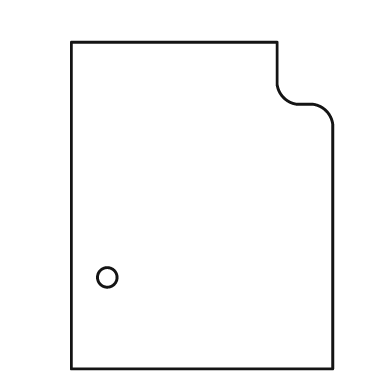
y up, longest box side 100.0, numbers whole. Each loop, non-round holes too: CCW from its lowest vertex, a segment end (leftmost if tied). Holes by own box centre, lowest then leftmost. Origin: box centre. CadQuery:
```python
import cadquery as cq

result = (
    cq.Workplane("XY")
    .moveTo(-40.0, -50.0)
    .lineTo(40.0, -50.0)
    .lineTo(40.0, 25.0)
    .threePointArc((38.0, 29.0), (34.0, 31.0))
    .lineTo(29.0, 31.0)
    .threePointArc((25.0, 33.0), (23.0, 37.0))
    .lineTo(23.0, 50.0)
    .lineTo(-40.0, 50.0)
    .close()
    .moveTo(-29.0, -22.0)
    .circle(3.0)
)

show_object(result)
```